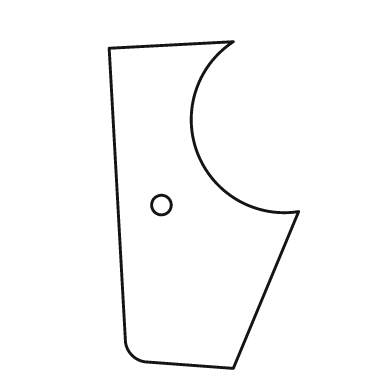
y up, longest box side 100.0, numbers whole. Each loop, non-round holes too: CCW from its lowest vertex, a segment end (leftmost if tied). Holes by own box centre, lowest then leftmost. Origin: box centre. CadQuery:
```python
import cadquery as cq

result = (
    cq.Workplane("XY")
    .moveTo(9.0, -50.0)
    .lineTo(29.0, -2.0)
    .threePointArc((-2.0, 16.0), (9.0, 50.0))
    .lineTo(-29.0, 48.0)
    .lineTo(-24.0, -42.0)
    .threePointArc((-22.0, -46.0), (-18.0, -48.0))
    .close()
    .moveTo(-13.0, 0.0)
    .circle(3.0)
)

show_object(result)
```